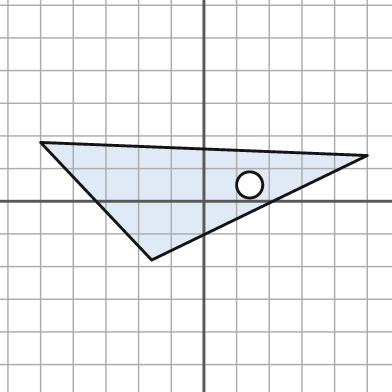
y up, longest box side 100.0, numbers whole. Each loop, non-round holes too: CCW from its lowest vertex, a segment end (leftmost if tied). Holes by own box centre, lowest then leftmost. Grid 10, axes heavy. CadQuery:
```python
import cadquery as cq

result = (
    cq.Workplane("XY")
    .moveTo(-16.0, -18.0)
    .lineTo(50.0, 14.0)
    .lineTo(-50.0, 18.0)
    .close()
    .moveTo(14.0, 5.0)
    .circle(4.0)
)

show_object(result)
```